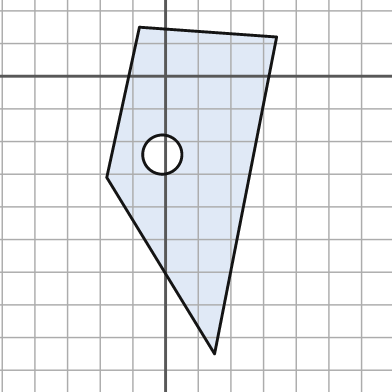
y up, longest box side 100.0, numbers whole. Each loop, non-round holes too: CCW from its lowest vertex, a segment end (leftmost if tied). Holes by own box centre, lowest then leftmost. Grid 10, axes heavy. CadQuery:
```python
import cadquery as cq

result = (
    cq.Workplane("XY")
    .moveTo(15.0, -85.0)
    .lineTo(34.0, 12.0)
    .lineTo(-8.0, 15.0)
    .lineTo(-18.0, -31.0)
    .close()
    .moveTo(-1.0, -24.0)
    .circle(6.0)
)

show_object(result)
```